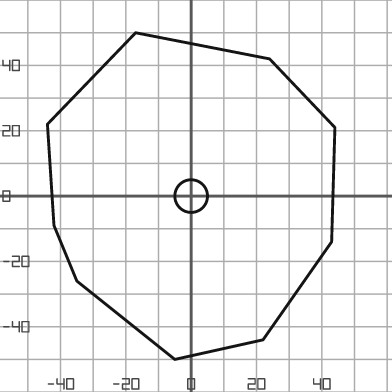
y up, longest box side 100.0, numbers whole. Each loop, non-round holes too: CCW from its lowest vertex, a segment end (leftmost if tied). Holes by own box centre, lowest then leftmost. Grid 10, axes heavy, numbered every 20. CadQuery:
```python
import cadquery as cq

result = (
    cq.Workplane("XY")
    .moveTo(-5.0, -50.0)
    .lineTo(22.0, -44.0)
    .lineTo(43.0, -14.0)
    .lineTo(44.0, 21.0)
    .lineTo(24.0, 42.0)
    .lineTo(-17.0, 50.0)
    .lineTo(-44.0, 22.0)
    .lineTo(-42.0, -9.0)
    .lineTo(-35.0, -26.0)
    .close()
    .moveTo(0.0, 0.0)
    .circle(5.0)
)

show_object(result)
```